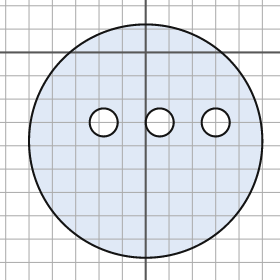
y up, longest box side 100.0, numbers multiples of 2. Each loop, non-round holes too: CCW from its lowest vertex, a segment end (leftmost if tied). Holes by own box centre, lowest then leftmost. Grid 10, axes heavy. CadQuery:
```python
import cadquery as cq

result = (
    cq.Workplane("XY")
    .moveTo(0.0, -38.0)
    .circle(50.0)
    .moveTo(-18.0, -30.0)
    .circle(6.0)
    .moveTo(6.0, -30.0)
    .circle(6.0)
    .moveTo(30.0, -30.0)
    .circle(6.0)
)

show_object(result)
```